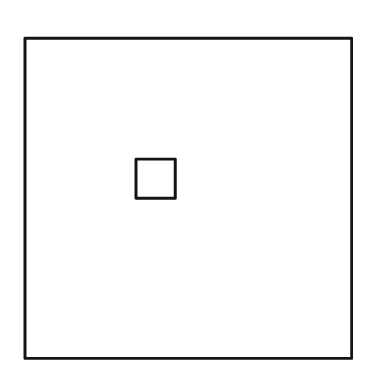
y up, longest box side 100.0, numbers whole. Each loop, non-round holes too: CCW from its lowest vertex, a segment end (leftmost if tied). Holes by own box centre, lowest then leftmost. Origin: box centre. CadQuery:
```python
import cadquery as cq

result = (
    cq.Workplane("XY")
    .moveTo(-50.0, -49.0)
    .lineTo(50.0, -49.0)
    .lineTo(50.0, 49.0)
    .lineTo(-50.0, 49.0)
    .close()
    .moveTo(-16.0, 0.0)
    .lineTo(-4.0, 0.0)
    .lineTo(-4.0, 12.0)
    .lineTo(-16.0, 12.0)
    .close()
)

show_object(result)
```